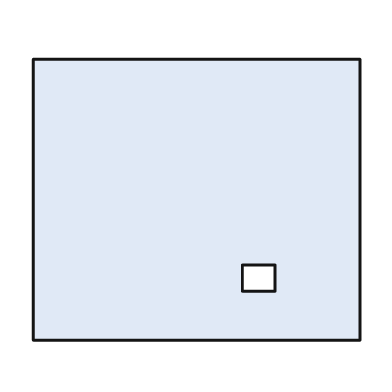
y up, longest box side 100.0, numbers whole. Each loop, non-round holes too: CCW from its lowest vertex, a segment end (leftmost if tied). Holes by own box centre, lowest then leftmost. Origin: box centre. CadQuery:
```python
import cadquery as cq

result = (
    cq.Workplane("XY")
    .moveTo(-50.0, -43.0)
    .lineTo(50.0, -43.0)
    .lineTo(50.0, 43.0)
    .lineTo(-50.0, 43.0)
    .close()
    .moveTo(14.0, -28.0)
    .lineTo(24.0, -28.0)
    .lineTo(24.0, -20.0)
    .lineTo(14.0, -20.0)
    .close()
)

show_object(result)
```